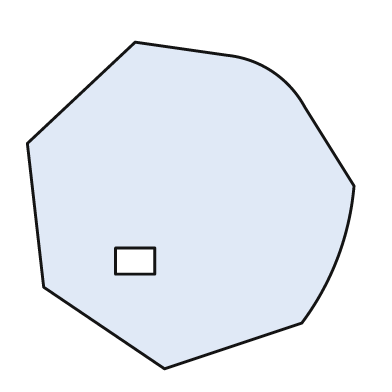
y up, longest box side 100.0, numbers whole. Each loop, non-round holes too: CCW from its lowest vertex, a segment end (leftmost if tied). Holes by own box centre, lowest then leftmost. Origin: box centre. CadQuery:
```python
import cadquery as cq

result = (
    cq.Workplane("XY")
    .moveTo(-8.0, -50.0)
    .lineTo(34.0, -36.0)
    .threePointArc((45.0, -16.0), (50.0, 6.0))
    .lineTo(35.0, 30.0)
    .threePointArc((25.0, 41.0), (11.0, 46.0))
    .lineTo(-17.0, 50.0)
    .lineTo(-50.0, 19.0)
    .lineTo(-45.0, -25.0)
    .close()
    .moveTo(-23.0, -21.0)
    .lineTo(-11.0, -21.0)
    .lineTo(-11.0, -13.0)
    .lineTo(-23.0, -13.0)
    .close()
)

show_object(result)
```